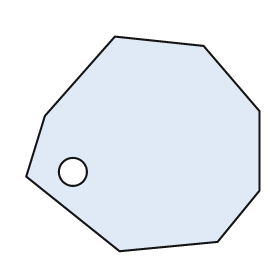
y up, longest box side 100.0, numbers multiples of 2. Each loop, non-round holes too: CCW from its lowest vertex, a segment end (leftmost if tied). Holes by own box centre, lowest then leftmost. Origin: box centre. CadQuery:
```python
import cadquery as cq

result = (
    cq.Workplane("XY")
    .moveTo(-10.0, -46.0)
    .lineTo(32.0, -42.0)
    .lineTo(50.0, -20.0)
    .lineTo(50.0, 14.0)
    .lineTo(26.0, 42.0)
    .lineTo(-12.0, 46.0)
    .lineTo(-42.0, 12.0)
    .lineTo(-50.0, -14.0)
    .close()
    .moveTo(-30.0, -12.0)
    .circle(6.0)
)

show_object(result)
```